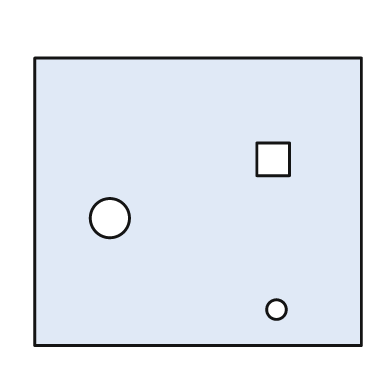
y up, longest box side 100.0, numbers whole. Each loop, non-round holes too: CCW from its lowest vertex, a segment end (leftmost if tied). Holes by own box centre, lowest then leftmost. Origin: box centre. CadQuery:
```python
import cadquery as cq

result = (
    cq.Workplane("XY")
    .moveTo(-50.0, -44.0)
    .lineTo(50.0, -44.0)
    .lineTo(50.0, 44.0)
    .lineTo(-50.0, 44.0)
    .close()
    .moveTo(24.0, -33.0)
    .circle(3.0)
    .moveTo(-27.0, -5.0)
    .circle(6.0)
    .moveTo(18.0, 8.0)
    .lineTo(28.0, 8.0)
    .lineTo(28.0, 18.0)
    .lineTo(18.0, 18.0)
    .close()
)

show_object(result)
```